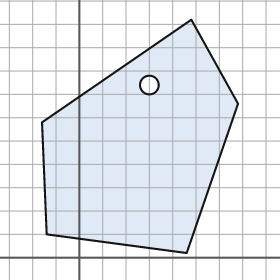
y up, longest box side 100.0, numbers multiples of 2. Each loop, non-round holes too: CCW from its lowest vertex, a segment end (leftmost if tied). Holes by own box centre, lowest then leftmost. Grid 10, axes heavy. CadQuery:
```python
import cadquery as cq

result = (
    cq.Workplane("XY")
    .moveTo(46.0, 2.0)
    .lineTo(68.0, 66.0)
    .lineTo(48.0, 102.0)
    .lineTo(-16.0, 58.0)
    .lineTo(-14.0, 10.0)
    .close()
    .moveTo(30.0, 74.0)
    .circle(4.0)
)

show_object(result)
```